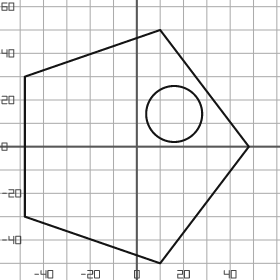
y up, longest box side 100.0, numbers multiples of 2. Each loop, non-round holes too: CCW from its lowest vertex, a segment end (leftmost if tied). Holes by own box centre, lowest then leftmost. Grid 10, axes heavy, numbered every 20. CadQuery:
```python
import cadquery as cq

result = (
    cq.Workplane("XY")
    .moveTo(10.0, -50.0)
    .lineTo(48.0, 0.0)
    .lineTo(10.0, 50.0)
    .lineTo(-48.0, 30.0)
    .lineTo(-48.0, -30.0)
    .close()
    .moveTo(16.0, 14.0)
    .circle(12.0)
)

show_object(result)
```